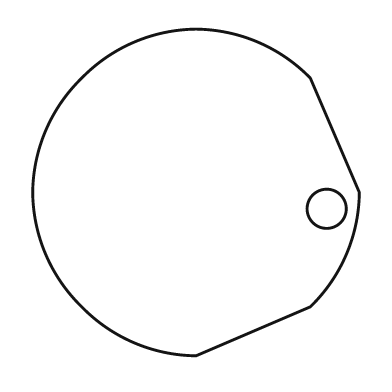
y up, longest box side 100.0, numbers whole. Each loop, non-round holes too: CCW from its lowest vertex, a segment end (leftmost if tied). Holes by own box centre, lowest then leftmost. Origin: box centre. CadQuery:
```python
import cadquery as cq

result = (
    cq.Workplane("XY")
    .moveTo(0.0, -50.0)
    .lineTo(35.0, -35.0)
    .threePointArc((46.0, -19.0), (50.0, 0.0))
    .lineTo(35.0, 35.0)
    .threePointArc((19.0, 46.0), (0.0, 50.0))
    .threePointArc((-19.0, 46.0), (-35.0, 35.0))
    .threePointArc((-46.0, 19.0), (-50.0, 0.0))
    .threePointArc((-46.0, -19.0), (-35.0, -35.0))
    .threePointArc((-19.0, -46.0), (0.0, -50.0))
    .close()
    .moveTo(40.0, -5.0)
    .circle(6.0)
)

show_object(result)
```